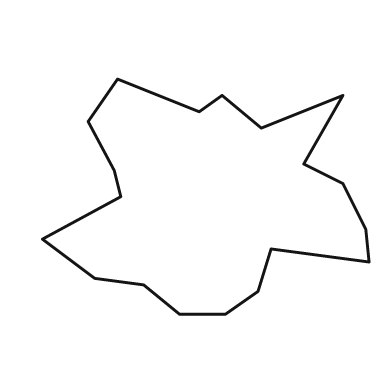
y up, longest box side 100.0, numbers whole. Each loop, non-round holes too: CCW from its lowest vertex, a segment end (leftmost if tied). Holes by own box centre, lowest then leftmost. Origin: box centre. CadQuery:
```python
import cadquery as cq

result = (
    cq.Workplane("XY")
    .moveTo(-8.0, -36.0)
    .lineTo(6.0, -36.0)
    .lineTo(16.0, -29.0)
    .lineTo(20.0, -16.0)
    .lineTo(50.0, -20.0)
    .lineTo(49.0, -10.0)
    .lineTo(42.0, 4.0)
    .lineTo(30.0, 10.0)
    .lineTo(42.0, 31.0)
    .lineTo(17.0, 21.0)
    .lineTo(5.0, 31.0)
    .lineTo(-2.0, 26.0)
    .lineTo(-27.0, 36.0)
    .lineTo(-36.0, 23.0)
    .lineTo(-28.0, 8.0)
    .lineTo(-26.0, 0.0)
    .lineTo(-50.0, -13.0)
    .lineTo(-34.0, -25.0)
    .lineTo(-19.0, -27.0)
    .close()
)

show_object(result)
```